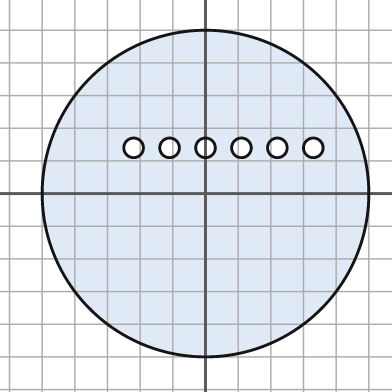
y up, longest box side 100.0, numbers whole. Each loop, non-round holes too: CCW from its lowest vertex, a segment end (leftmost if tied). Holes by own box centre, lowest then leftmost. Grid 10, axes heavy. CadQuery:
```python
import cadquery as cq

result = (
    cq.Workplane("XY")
    .moveTo(0.0, 0.0)
    .circle(50.0)
    .moveTo(-22.0, 14.0)
    .circle(3.0)
    .moveTo(-11.0, 14.0)
    .circle(3.0)
    .moveTo(0.0, 14.0)
    .circle(3.0)
    .moveTo(11.0, 14.0)
    .circle(3.0)
    .moveTo(22.0, 14.0)
    .circle(3.0)
    .moveTo(33.0, 14.0)
    .circle(3.0)
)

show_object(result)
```